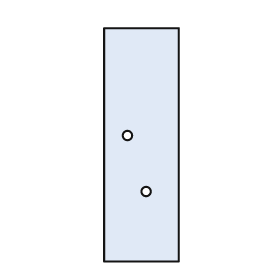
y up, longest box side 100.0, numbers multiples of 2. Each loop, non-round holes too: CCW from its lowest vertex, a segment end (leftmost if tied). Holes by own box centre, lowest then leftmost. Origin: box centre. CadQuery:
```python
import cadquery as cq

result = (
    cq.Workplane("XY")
    .moveTo(-16.0, -50.0)
    .lineTo(16.0, -50.0)
    .lineTo(16.0, 50.0)
    .lineTo(-16.0, 50.0)
    .close()
    .moveTo(2.0, -20.0)
    .circle(2.0)
    .moveTo(-6.0, 4.0)
    .circle(2.0)
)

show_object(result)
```